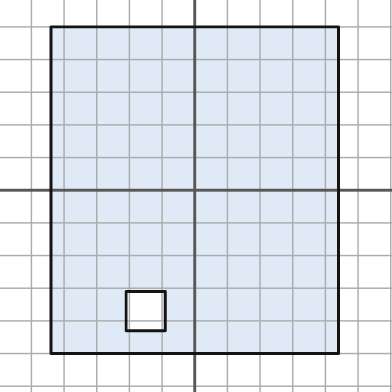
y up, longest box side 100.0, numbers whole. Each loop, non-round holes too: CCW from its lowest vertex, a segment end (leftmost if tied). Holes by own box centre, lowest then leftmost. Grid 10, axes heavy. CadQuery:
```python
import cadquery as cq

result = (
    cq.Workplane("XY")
    .moveTo(-44.0, -50.0)
    .lineTo(44.0, -50.0)
    .lineTo(44.0, 50.0)
    .lineTo(-44.0, 50.0)
    .close()
    .moveTo(-21.0, -43.0)
    .lineTo(-9.0, -43.0)
    .lineTo(-9.0, -31.0)
    .lineTo(-21.0, -31.0)
    .close()
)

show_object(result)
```